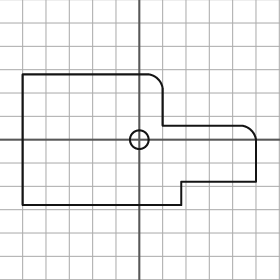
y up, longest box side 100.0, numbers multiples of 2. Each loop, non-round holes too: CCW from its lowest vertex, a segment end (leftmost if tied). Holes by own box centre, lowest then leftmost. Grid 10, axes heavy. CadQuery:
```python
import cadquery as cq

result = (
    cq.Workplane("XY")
    .moveTo(-50.0, -28.0)
    .lineTo(18.0, -28.0)
    .lineTo(18.0, -18.0)
    .lineTo(50.0, -18.0)
    .lineTo(50.0, 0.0)
    .threePointArc((48.0, 4.0), (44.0, 6.0))
    .lineTo(10.0, 6.0)
    .lineTo(10.0, 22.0)
    .threePointArc((8.0, 26.0), (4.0, 28.0))
    .lineTo(-50.0, 28.0)
    .close()
    .moveTo(0.0, 0.0)
    .circle(4.0)
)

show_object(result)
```